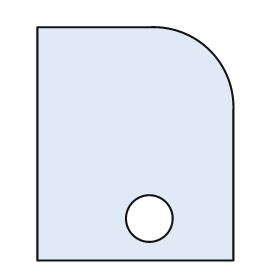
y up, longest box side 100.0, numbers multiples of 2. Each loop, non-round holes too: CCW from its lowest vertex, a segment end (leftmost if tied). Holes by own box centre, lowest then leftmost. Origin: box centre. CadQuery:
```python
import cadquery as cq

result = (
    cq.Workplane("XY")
    .moveTo(-42.0, -50.0)
    .lineTo(42.0, -50.0)
    .lineTo(42.0, 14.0)
    .threePointArc((32.0, 40.0), (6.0, 50.0))
    .lineTo(-42.0, 50.0)
    .close()
    .moveTo(6.0, -32.0)
    .circle(10.0)
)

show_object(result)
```